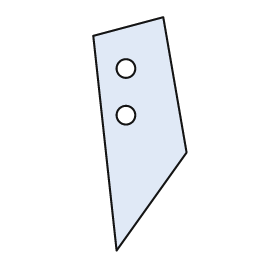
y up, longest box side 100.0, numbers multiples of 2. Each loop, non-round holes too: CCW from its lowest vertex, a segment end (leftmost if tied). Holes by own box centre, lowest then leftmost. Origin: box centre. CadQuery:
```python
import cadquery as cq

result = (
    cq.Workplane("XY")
    .moveTo(-10.0, -50.0)
    .lineTo(20.0, -8.0)
    .lineTo(10.0, 50.0)
    .lineTo(-20.0, 42.0)
    .close()
    .moveTo(-6.0, 8.0)
    .circle(4.0)
    .moveTo(-6.0, 28.0)
    .circle(4.0)
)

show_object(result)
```